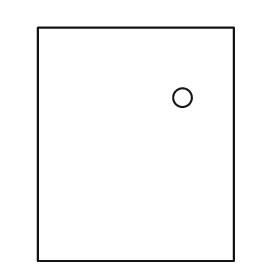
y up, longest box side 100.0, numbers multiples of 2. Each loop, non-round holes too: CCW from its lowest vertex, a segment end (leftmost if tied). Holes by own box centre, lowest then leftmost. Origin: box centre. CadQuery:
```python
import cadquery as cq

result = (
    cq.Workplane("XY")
    .moveTo(-42.0, -50.0)
    .lineTo(42.0, -50.0)
    .lineTo(42.0, 50.0)
    .lineTo(-42.0, 50.0)
    .close()
    .moveTo(20.0, 20.0)
    .circle(4.0)
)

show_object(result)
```